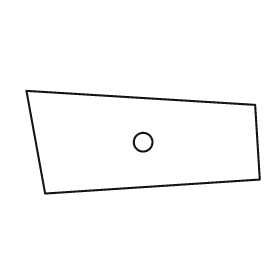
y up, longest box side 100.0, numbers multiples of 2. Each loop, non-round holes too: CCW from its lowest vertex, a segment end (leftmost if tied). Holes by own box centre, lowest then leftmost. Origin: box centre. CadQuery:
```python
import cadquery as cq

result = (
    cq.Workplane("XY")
    .moveTo(-42.0, -22.0)
    .lineTo(50.0, -16.0)
    .lineTo(48.0, 16.0)
    .lineTo(-50.0, 22.0)
    .close()
    .moveTo(0.0, 0.0)
    .circle(4.0)
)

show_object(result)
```